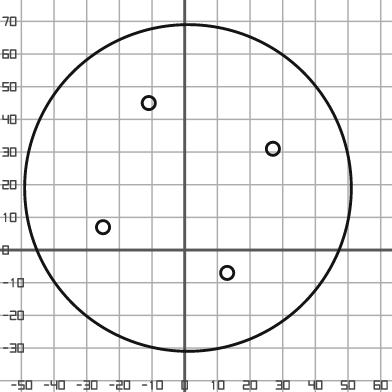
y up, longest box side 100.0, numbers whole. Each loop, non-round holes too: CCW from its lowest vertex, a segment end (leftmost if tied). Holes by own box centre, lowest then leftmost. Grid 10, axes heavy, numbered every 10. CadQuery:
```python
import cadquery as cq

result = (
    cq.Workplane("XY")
    .moveTo(1.0, 19.0)
    .circle(50.0)
    .moveTo(13.0, -7.0)
    .circle(2.0)
    .moveTo(-25.0, 7.0)
    .circle(2.0)
    .moveTo(27.0, 31.0)
    .circle(2.0)
    .moveTo(-11.0, 45.0)
    .circle(2.0)
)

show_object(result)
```